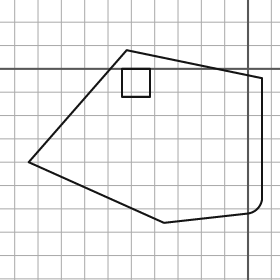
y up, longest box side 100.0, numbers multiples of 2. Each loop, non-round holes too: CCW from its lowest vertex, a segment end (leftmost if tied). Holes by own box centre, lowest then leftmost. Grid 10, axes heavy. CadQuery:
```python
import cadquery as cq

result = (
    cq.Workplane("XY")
    .moveTo(-36.0, -66.0)
    .lineTo(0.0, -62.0)
    .threePointArc((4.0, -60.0), (6.0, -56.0))
    .lineTo(6.0, -4.0)
    .lineTo(-52.0, 8.0)
    .lineTo(-94.0, -40.0)
    .close()
    .moveTo(-54.0, -12.0)
    .lineTo(-42.0, -12.0)
    .lineTo(-42.0, 0.0)
    .lineTo(-54.0, 0.0)
    .close()
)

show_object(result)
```